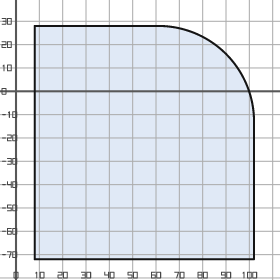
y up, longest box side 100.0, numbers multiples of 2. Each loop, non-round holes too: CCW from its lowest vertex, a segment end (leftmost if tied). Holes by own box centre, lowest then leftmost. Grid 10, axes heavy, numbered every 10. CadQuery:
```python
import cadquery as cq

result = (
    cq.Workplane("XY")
    .moveTo(8.0, -72.0)
    .lineTo(102.0, -72.0)
    .lineTo(102.0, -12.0)
    .threePointArc((90.0, 16.0), (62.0, 28.0))
    .lineTo(8.0, 28.0)
    .close()
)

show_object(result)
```